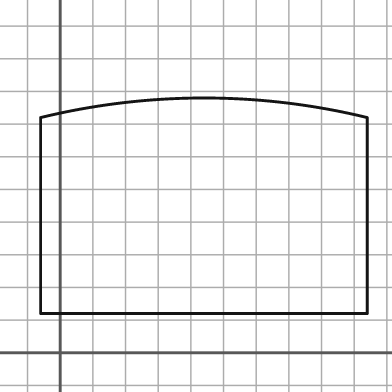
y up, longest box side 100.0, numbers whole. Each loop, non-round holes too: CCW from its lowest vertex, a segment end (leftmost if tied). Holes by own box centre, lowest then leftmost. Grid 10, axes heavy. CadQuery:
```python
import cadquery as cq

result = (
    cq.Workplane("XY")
    .moveTo(-6.0, 12.0)
    .lineTo(94.0, 12.0)
    .lineTo(94.0, 72.0)
    .threePointArc((44.0, 78.0), (-6.0, 72.0))
    .close()
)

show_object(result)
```